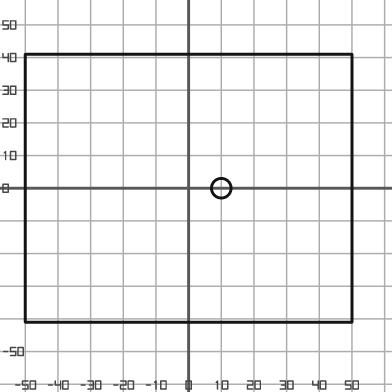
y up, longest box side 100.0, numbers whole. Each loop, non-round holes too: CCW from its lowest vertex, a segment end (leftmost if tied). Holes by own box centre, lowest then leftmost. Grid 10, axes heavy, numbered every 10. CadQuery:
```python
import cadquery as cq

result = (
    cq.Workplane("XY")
    .moveTo(-50.0, -41.0)
    .lineTo(50.0, -41.0)
    .lineTo(50.0, 41.0)
    .lineTo(-50.0, 41.0)
    .close()
    .moveTo(10.0, 0.0)
    .circle(3.0)
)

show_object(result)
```